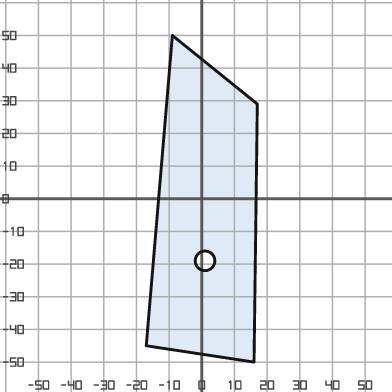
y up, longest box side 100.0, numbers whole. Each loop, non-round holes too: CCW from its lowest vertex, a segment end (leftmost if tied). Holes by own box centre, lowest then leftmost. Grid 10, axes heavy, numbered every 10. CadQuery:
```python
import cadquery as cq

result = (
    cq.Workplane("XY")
    .moveTo(16.0, -50.0)
    .lineTo(17.0, 29.0)
    .lineTo(-9.0, 50.0)
    .lineTo(-17.0, -45.0)
    .close()
    .moveTo(1.0, -19.0)
    .circle(3.0)
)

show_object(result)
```